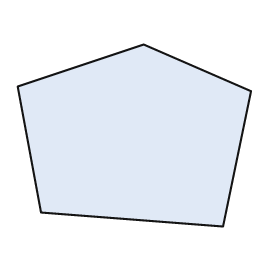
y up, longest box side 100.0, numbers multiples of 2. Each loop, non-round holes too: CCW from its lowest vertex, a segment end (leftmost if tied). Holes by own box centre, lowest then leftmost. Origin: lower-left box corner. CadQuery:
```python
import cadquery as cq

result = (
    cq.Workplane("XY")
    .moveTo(88.0, 0.0)
    .lineTo(100.0, 58.0)
    .lineTo(54.0, 78.0)
    .lineTo(0.0, 60.0)
    .lineTo(10.0, 6.0)
    .close()
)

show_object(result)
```